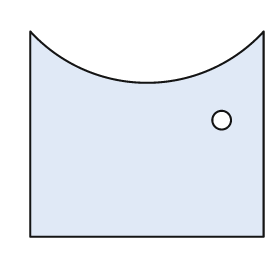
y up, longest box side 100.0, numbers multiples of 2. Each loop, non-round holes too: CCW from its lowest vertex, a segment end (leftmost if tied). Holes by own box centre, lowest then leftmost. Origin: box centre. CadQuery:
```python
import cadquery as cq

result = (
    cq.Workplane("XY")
    .moveTo(-50.0, -44.0)
    .lineTo(50.0, -44.0)
    .lineTo(50.0, 44.0)
    .threePointArc((0.0, 22.0), (-50.0, 44.0))
    .close()
    .moveTo(32.0, 6.0)
    .circle(4.0)
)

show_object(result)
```